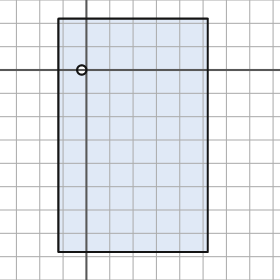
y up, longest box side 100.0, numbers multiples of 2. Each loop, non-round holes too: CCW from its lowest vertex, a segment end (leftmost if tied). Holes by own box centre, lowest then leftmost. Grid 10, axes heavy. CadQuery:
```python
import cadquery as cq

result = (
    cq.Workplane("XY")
    .moveTo(-12.0, -78.0)
    .lineTo(52.0, -78.0)
    .lineTo(52.0, 22.0)
    .lineTo(-12.0, 22.0)
    .close()
    .moveTo(-2.0, 0.0)
    .circle(2.0)
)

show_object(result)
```